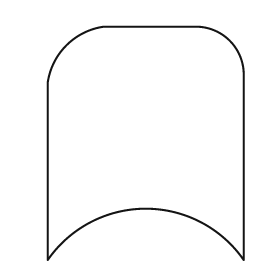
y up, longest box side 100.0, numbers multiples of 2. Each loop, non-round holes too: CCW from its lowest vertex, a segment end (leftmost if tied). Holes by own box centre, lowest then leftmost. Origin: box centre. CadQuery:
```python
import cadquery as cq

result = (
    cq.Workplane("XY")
    .moveTo(-42.0, -50.0)
    .threePointArc((0.0, -28.0), (42.0, -50.0))
    .lineTo(42.0, 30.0)
    .threePointArc((36.0, 44.0), (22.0, 50.0))
    .lineTo(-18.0, 50.0)
    .threePointArc((-34.0, 42.0), (-42.0, 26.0))
    .close()
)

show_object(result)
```